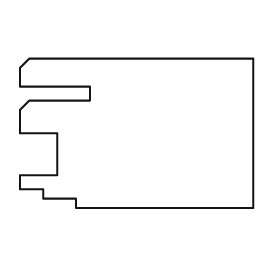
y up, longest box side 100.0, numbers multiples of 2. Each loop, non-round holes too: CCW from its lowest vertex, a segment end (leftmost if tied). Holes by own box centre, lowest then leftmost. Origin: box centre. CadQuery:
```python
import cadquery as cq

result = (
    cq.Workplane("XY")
    .moveTo(-26.0, -32.0)
    .lineTo(50.0, -32.0)
    .lineTo(50.0, 32.0)
    .lineTo(-46.0, 32.0)
    .lineTo(-50.0, 28.0)
    .lineTo(-50.0, 20.0)
    .lineTo(-20.0, 20.0)
    .lineTo(-20.0, 14.0)
    .lineTo(-46.0, 14.0)
    .lineTo(-50.0, 10.0)
    .lineTo(-50.0, 0.0)
    .lineTo(-34.0, 0.0)
    .lineTo(-34.0, -18.0)
    .lineTo(-50.0, -18.0)
    .lineTo(-50.0, -24.0)
    .lineTo(-40.0, -24.0)
    .lineTo(-40.0, -28.0)
    .lineTo(-26.0, -28.0)
    .close()
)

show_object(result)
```